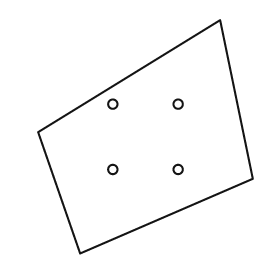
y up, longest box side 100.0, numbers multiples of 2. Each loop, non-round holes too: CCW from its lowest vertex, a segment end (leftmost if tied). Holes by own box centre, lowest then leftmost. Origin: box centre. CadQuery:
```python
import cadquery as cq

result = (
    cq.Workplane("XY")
    .moveTo(-28.0, -50.0)
    .lineTo(46.0, -18.0)
    .lineTo(32.0, 50.0)
    .lineTo(-46.0, 2.0)
    .close()
    .moveTo(-14.0, -14.0)
    .circle(2.0)
    .moveTo(14.0, -14.0)
    .circle(2.0)
    .moveTo(-14.0, 14.0)
    .circle(2.0)
    .moveTo(14.0, 14.0)
    .circle(2.0)
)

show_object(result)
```